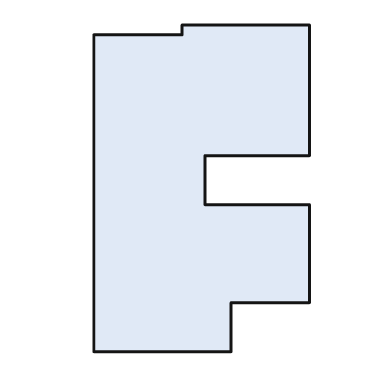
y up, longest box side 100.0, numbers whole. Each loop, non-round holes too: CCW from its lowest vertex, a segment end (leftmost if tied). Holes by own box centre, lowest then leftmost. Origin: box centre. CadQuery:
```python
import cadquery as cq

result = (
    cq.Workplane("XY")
    .moveTo(-33.0, -50.0)
    .lineTo(9.0, -50.0)
    .lineTo(9.0, -35.0)
    .lineTo(33.0, -35.0)
    .lineTo(33.0, -5.0)
    .lineTo(1.0, -5.0)
    .lineTo(1.0, 10.0)
    .lineTo(33.0, 10.0)
    .lineTo(33.0, 50.0)
    .lineTo(-6.0, 50.0)
    .lineTo(-6.0, 47.0)
    .lineTo(-33.0, 47.0)
    .close()
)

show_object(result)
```